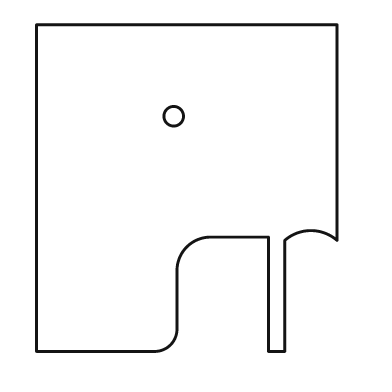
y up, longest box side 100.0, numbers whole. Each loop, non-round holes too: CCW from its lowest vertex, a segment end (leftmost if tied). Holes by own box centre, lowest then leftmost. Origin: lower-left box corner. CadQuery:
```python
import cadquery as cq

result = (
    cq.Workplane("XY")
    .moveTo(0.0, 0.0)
    .lineTo(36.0, 0.0)
    .threePointArc((41.0, 2.0), (43.0, 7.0))
    .lineTo(43.0, 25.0)
    .threePointArc((46.0, 32.0), (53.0, 35.0))
    .lineTo(71.0, 35.0)
    .lineTo(71.0, 0.0)
    .lineTo(76.0, 0.0)
    .lineTo(76.0, 34.0)
    .threePointArc((84.0, 37.0), (92.0, 34.0))
    .lineTo(92.0, 100.0)
    .lineTo(0.0, 100.0)
    .close()
    .moveTo(42.0, 72.0)
    .circle(3.0)
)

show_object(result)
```